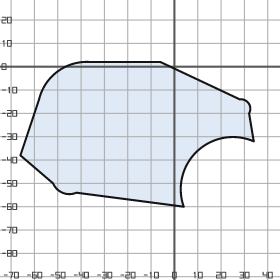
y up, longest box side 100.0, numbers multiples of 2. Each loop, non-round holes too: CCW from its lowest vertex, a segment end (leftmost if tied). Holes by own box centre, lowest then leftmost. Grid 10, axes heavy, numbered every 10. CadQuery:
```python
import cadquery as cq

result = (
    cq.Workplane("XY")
    .moveTo(4.0, -60.0)
    .threePointArc((10.0, -36.0), (34.0, -32.0))
    .lineTo(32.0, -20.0)
    .threePointArc((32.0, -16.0), (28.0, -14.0))
    .lineTo(-6.0, 2.0)
    .lineTo(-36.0, 2.0)
    .threePointArc((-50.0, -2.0), (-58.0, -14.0))
    .lineTo(-66.0, -38.0)
    .lineTo(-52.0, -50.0)
    .threePointArc((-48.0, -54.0), (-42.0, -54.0))
    .close()
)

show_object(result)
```